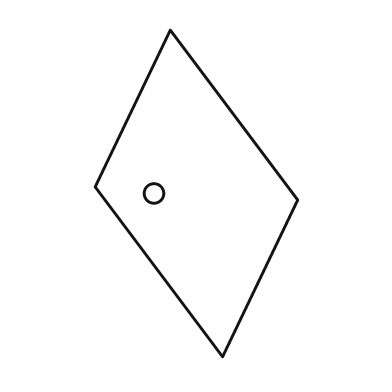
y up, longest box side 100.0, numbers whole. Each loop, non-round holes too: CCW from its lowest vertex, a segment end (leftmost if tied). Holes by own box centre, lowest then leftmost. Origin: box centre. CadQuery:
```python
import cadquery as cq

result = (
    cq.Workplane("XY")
    .moveTo(8.0, -50.0)
    .lineTo(31.0, -2.0)
    .lineTo(-8.0, 50.0)
    .lineTo(-31.0, 2.0)
    .close()
    .moveTo(-13.0, 0.0)
    .circle(3.0)
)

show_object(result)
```